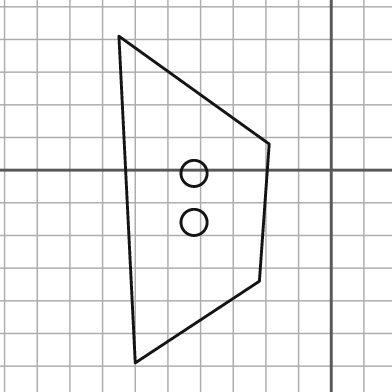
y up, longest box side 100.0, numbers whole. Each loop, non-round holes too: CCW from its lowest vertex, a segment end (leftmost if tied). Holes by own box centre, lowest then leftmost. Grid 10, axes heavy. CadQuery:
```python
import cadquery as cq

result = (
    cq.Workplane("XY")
    .moveTo(-60.0, -59.0)
    .lineTo(-22.0, -34.0)
    .lineTo(-19.0, 8.0)
    .lineTo(-65.0, 41.0)
    .close()
    .moveTo(-42.0, -16.0)
    .circle(4.0)
    .moveTo(-42.0, -1.0)
    .circle(4.0)
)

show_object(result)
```